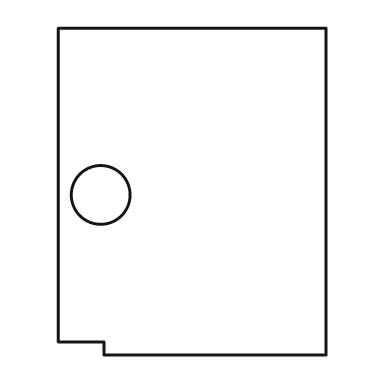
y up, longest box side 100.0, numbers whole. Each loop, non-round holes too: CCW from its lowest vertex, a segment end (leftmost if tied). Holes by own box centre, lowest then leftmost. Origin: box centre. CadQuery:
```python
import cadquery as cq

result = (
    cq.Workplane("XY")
    .moveTo(-27.0, -50.0)
    .lineTo(41.0, -50.0)
    .lineTo(41.0, 50.0)
    .lineTo(-41.0, 50.0)
    .lineTo(-41.0, -46.0)
    .lineTo(-27.0, -46.0)
    .close()
    .moveTo(-28.0, -1.0)
    .circle(9.0)
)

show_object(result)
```